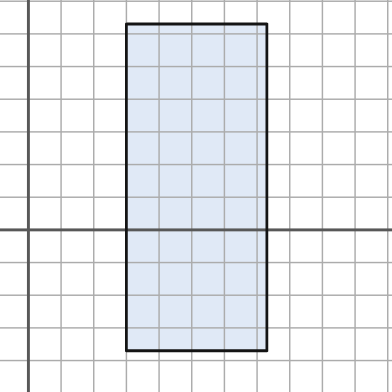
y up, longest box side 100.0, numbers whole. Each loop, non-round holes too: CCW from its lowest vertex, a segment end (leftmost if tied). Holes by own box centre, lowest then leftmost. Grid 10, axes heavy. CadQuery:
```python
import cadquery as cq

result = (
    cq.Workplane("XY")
    .moveTo(30.0, -37.0)
    .lineTo(73.0, -37.0)
    .lineTo(73.0, 63.0)
    .lineTo(30.0, 63.0)
    .close()
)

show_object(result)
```